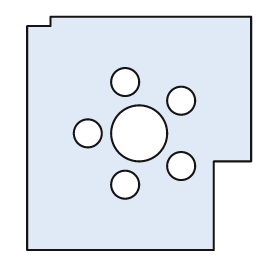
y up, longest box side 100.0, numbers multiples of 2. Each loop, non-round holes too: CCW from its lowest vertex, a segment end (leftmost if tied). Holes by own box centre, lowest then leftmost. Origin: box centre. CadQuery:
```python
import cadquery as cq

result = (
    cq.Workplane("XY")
    .moveTo(-48.0, -50.0)
    .lineTo(32.0, -50.0)
    .lineTo(32.0, -12.0)
    .lineTo(48.0, -12.0)
    .lineTo(48.0, 50.0)
    .lineTo(-38.0, 50.0)
    .lineTo(-38.0, 46.0)
    .lineTo(-48.0, 46.0)
    .close()
    .moveTo(-6.0, -22.0)
    .circle(6.0)
    .moveTo(18.0, -14.0)
    .circle(6.0)
    .moveTo(-22.0, 0.0)
    .circle(6.0)
    .moveTo(0.0, 0.0)
    .circle(12.0)
    .moveTo(18.0, 14.0)
    .circle(6.0)
    .moveTo(-6.0, 22.0)
    .circle(6.0)
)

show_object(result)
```